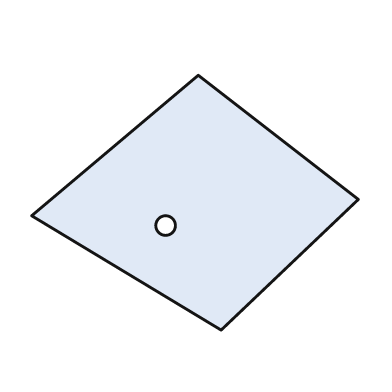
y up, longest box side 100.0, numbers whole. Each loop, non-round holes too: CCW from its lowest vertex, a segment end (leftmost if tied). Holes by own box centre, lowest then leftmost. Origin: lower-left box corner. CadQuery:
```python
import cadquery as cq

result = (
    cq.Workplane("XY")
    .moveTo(58.0, 0.0)
    .lineTo(100.0, 40.0)
    .lineTo(51.0, 78.0)
    .lineTo(0.0, 35.0)
    .close()
    .moveTo(41.0, 32.0)
    .circle(3.0)
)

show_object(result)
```